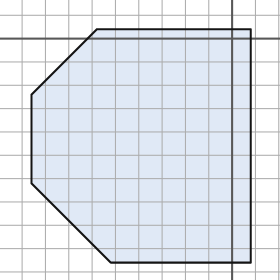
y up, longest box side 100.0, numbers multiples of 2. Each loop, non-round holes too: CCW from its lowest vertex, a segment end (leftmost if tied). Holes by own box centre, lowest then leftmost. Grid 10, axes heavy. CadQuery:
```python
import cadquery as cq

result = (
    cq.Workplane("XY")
    .moveTo(-52.0, -96.0)
    .lineTo(8.0, -96.0)
    .lineTo(8.0, 4.0)
    .lineTo(-58.0, 4.0)
    .lineTo(-86.0, -24.0)
    .lineTo(-86.0, -62.0)
    .close()
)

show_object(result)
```